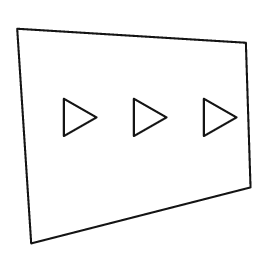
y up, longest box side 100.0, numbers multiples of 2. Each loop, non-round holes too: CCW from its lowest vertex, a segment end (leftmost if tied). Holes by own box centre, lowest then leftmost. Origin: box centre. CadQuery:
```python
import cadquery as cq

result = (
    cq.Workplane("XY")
    .moveTo(-44.0, -46.0)
    .lineTo(50.0, -22.0)
    .lineTo(48.0, 40.0)
    .lineTo(-50.0, 46.0)
    .close()
    .moveTo(-30.0, 0.0)
    .lineTo(-16.0, 8.0)
    .lineTo(-30.0, 16.0)
    .close()
    .moveTo(0.0, 0.0)
    .lineTo(14.0, 8.0)
    .lineTo(0.0, 16.0)
    .close()
    .moveTo(30.0, 0.0)
    .lineTo(44.0, 8.0)
    .lineTo(30.0, 16.0)
    .close()
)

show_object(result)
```